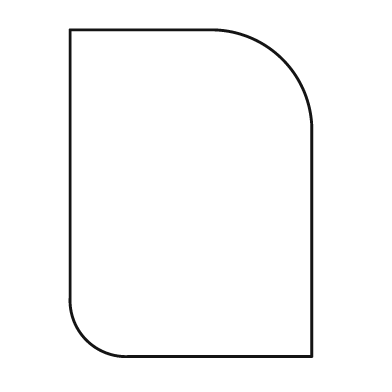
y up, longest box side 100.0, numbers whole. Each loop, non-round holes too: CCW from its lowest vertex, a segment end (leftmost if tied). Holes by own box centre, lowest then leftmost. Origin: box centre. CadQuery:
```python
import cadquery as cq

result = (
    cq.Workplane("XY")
    .moveTo(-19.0, -50.0)
    .lineTo(37.0, -50.0)
    .lineTo(37.0, 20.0)
    .threePointArc((28.0, 41.0), (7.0, 50.0))
    .lineTo(-37.0, 50.0)
    .lineTo(-37.0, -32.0)
    .threePointArc((-32.0, -45.0), (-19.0, -50.0))
    .close()
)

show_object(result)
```